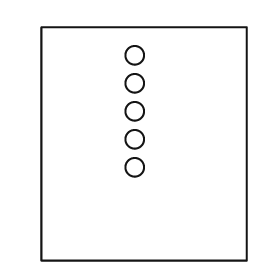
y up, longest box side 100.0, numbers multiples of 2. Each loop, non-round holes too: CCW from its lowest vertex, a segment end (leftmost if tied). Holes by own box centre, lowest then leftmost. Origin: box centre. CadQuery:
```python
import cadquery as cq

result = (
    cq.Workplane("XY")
    .moveTo(-44.0, -50.0)
    .lineTo(44.0, -50.0)
    .lineTo(44.0, 50.0)
    .lineTo(-44.0, 50.0)
    .close()
    .moveTo(-4.0, -10.0)
    .circle(4.0)
    .moveTo(-4.0, 2.0)
    .circle(4.0)
    .moveTo(-4.0, 14.0)
    .circle(4.0)
    .moveTo(-4.0, 26.0)
    .circle(4.0)
    .moveTo(-4.0, 38.0)
    .circle(4.0)
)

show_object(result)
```